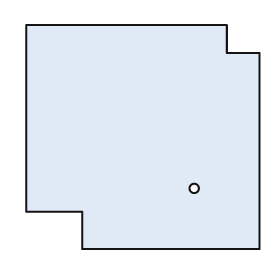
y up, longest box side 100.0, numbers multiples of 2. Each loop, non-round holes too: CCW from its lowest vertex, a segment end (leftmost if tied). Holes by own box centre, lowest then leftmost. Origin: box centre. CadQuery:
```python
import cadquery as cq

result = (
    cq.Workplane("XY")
    .moveTo(-26.0, -48.0)
    .lineTo(50.0, -48.0)
    .lineTo(50.0, 36.0)
    .lineTo(36.0, 36.0)
    .lineTo(36.0, 48.0)
    .lineTo(-50.0, 48.0)
    .lineTo(-50.0, -32.0)
    .lineTo(-26.0, -32.0)
    .close()
    .moveTo(22.0, -22.0)
    .circle(2.0)
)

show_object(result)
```